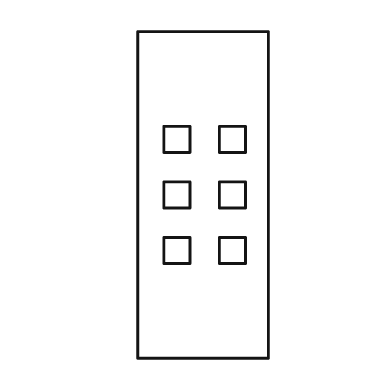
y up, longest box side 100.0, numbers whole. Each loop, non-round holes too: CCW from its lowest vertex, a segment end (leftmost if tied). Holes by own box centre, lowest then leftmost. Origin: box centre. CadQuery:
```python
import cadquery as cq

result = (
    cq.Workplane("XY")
    .moveTo(-20.0, -50.0)
    .lineTo(20.0, -50.0)
    .lineTo(20.0, 50.0)
    .lineTo(-20.0, 50.0)
    .close()
    .moveTo(-12.0, -21.0)
    .lineTo(-4.0, -21.0)
    .lineTo(-4.0, -13.0)
    .lineTo(-12.0, -13.0)
    .close()
    .moveTo(5.0, -21.0)
    .lineTo(13.0, -21.0)
    .lineTo(13.0, -13.0)
    .lineTo(5.0, -13.0)
    .close()
    .moveTo(-12.0, -4.0)
    .lineTo(-4.0, -4.0)
    .lineTo(-4.0, 4.0)
    .lineTo(-12.0, 4.0)
    .close()
    .moveTo(5.0, -4.0)
    .lineTo(13.0, -4.0)
    .lineTo(13.0, 4.0)
    .lineTo(5.0, 4.0)
    .close()
    .moveTo(-12.0, 13.0)
    .lineTo(-4.0, 13.0)
    .lineTo(-4.0, 21.0)
    .lineTo(-12.0, 21.0)
    .close()
    .moveTo(5.0, 13.0)
    .lineTo(13.0, 13.0)
    .lineTo(13.0, 21.0)
    .lineTo(5.0, 21.0)
    .close()
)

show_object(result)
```